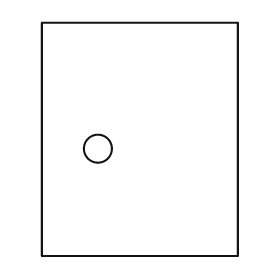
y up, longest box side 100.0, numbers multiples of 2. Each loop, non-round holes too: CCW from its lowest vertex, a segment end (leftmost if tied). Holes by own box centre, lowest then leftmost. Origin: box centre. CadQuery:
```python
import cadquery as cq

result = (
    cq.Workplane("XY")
    .moveTo(-42.0, -50.0)
    .lineTo(42.0, -50.0)
    .lineTo(42.0, 50.0)
    .lineTo(-42.0, 50.0)
    .close()
    .moveTo(-18.0, -4.0)
    .circle(6.0)
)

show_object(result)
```